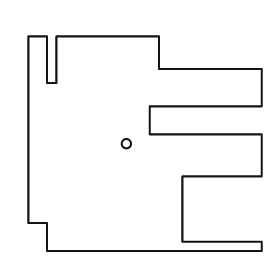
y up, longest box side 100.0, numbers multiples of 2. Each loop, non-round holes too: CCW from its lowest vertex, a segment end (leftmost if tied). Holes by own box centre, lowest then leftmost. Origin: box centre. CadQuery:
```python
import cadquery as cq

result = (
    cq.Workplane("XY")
    .moveTo(-42.0, -46.0)
    .lineTo(50.0, -46.0)
    .lineTo(50.0, -42.0)
    .lineTo(16.0, -42.0)
    .lineTo(16.0, -14.0)
    .lineTo(50.0, -14.0)
    .lineTo(50.0, 4.0)
    .lineTo(2.0, 4.0)
    .lineTo(2.0, 16.0)
    .lineTo(50.0, 16.0)
    .lineTo(50.0, 32.0)
    .lineTo(6.0, 32.0)
    .lineTo(6.0, 46.0)
    .lineTo(-38.0, 46.0)
    .lineTo(-38.0, 26.0)
    .lineTo(-42.0, 26.0)
    .lineTo(-42.0, 46.0)
    .lineTo(-50.0, 46.0)
    .lineTo(-50.0, -34.0)
    .lineTo(-42.0, -34.0)
    .close()
    .moveTo(-8.0, 0.0)
    .circle(2.0)
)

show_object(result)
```